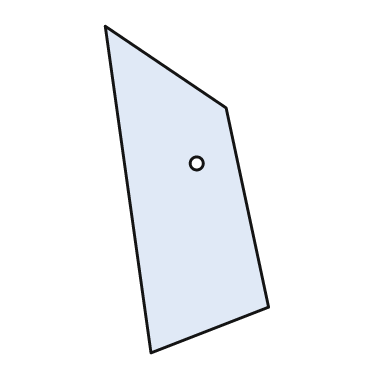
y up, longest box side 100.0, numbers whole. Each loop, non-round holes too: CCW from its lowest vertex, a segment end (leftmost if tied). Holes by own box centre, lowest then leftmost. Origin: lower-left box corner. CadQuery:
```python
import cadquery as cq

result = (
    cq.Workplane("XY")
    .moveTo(14.0, 0.0)
    .lineTo(50.0, 14.0)
    .lineTo(37.0, 75.0)
    .lineTo(0.0, 100.0)
    .close()
    .moveTo(28.0, 58.0)
    .circle(2.0)
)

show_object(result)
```